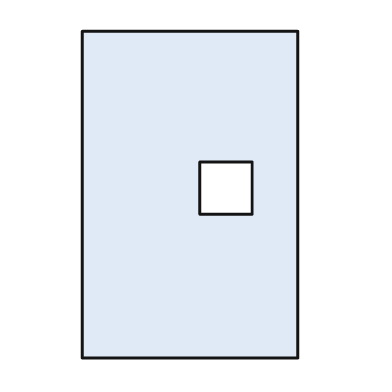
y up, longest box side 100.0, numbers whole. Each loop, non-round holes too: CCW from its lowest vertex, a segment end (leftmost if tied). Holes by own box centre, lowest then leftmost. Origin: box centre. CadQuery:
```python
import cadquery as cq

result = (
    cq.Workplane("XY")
    .moveTo(-33.0, -50.0)
    .lineTo(33.0, -50.0)
    .lineTo(33.0, 50.0)
    .lineTo(-33.0, 50.0)
    .close()
    .moveTo(3.0, -6.0)
    .lineTo(19.0, -6.0)
    .lineTo(19.0, 10.0)
    .lineTo(3.0, 10.0)
    .close()
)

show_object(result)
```